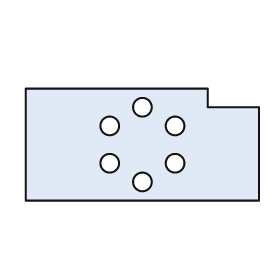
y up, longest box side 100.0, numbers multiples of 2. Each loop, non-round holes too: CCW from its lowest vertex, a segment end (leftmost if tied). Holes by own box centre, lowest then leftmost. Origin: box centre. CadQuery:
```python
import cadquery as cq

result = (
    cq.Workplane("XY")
    .moveTo(-50.0, -24.0)
    .lineTo(50.0, -24.0)
    .lineTo(50.0, 16.0)
    .lineTo(28.0, 16.0)
    .lineTo(28.0, 24.0)
    .lineTo(-50.0, 24.0)
    .close()
    .moveTo(0.0, -16.0)
    .circle(4.0)
    .moveTo(-14.0, -8.0)
    .circle(4.0)
    .moveTo(14.0, -8.0)
    .circle(4.0)
    .moveTo(-14.0, 8.0)
    .circle(4.0)
    .moveTo(14.0, 8.0)
    .circle(4.0)
    .moveTo(0.0, 16.0)
    .circle(4.0)
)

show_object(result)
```